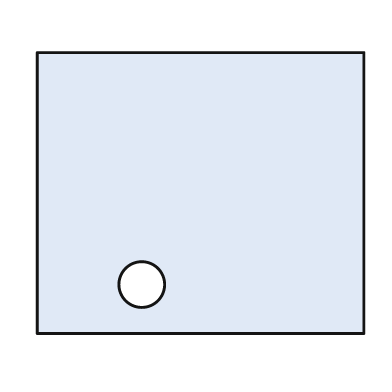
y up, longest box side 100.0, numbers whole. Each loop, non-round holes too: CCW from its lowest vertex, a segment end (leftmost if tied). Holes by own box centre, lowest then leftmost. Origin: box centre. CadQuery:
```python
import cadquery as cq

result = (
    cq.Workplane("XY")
    .moveTo(-50.0, -43.0)
    .lineTo(50.0, -43.0)
    .lineTo(50.0, 43.0)
    .lineTo(-50.0, 43.0)
    .close()
    .moveTo(-18.0, -28.0)
    .circle(7.0)
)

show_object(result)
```